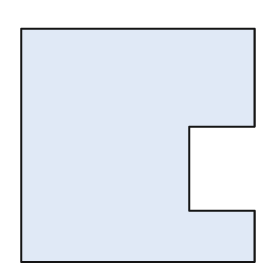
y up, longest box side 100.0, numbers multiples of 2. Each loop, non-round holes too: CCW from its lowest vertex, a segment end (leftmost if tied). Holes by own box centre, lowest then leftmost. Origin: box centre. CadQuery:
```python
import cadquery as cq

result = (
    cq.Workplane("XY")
    .moveTo(-50.0, -50.0)
    .lineTo(50.0, -50.0)
    .lineTo(50.0, -28.0)
    .lineTo(22.0, -28.0)
    .lineTo(22.0, 8.0)
    .lineTo(50.0, 8.0)
    .lineTo(50.0, 50.0)
    .lineTo(-50.0, 50.0)
    .close()
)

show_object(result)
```